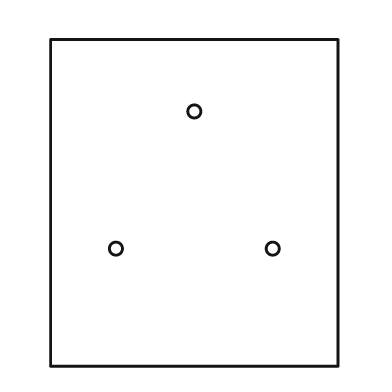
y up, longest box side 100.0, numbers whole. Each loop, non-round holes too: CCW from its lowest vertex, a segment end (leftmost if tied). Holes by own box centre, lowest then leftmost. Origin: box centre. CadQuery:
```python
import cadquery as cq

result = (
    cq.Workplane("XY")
    .moveTo(-44.0, -50.0)
    .lineTo(44.0, -50.0)
    .lineTo(44.0, 50.0)
    .lineTo(-44.0, 50.0)
    .close()
    .moveTo(-24.0, -14.0)
    .circle(2.0)
    .moveTo(24.0, -14.0)
    .circle(2.0)
    .moveTo(0.0, 28.0)
    .circle(2.0)
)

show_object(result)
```